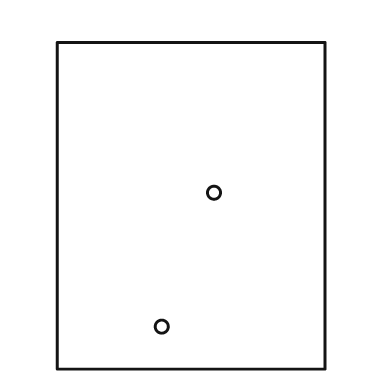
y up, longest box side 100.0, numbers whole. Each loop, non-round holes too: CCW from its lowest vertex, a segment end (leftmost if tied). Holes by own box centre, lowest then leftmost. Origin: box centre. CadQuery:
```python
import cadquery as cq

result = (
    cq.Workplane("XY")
    .moveTo(-41.0, -50.0)
    .lineTo(41.0, -50.0)
    .lineTo(41.0, 50.0)
    .lineTo(-41.0, 50.0)
    .close()
    .moveTo(-9.0, -37.0)
    .circle(2.0)
    .moveTo(7.0, 4.0)
    .circle(2.0)
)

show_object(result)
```